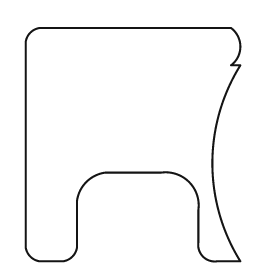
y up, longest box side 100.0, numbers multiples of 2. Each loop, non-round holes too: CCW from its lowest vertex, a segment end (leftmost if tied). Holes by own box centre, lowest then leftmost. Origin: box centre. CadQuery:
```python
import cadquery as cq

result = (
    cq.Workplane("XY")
    .moveTo(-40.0, -50.0)
    .lineTo(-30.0, -50.0)
    .threePointArc((-26.0, -48.0), (-24.0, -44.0))
    .lineTo(-24.0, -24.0)
    .threePointArc((-20.0, -16.0), (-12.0, -12.0))
    .lineTo(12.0, -12.0)
    .threePointArc((24.0, -16.0), (28.0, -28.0))
    .lineTo(28.0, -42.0)
    .threePointArc((30.0, -48.0), (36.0, -50.0))
    .lineTo(46.0, -50.0)
    .threePointArc((34.0, -8.0), (46.0, 34.0))
    .lineTo(42.0, 34.0)
    .threePointArc((46.0, 42.0), (42.0, 50.0))
    .lineTo(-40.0, 50.0)
    .threePointArc((-44.0, 48.0), (-46.0, 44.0))
    .lineTo(-46.0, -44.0)
    .threePointArc((-44.0, -48.0), (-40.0, -50.0))
    .close()
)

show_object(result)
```